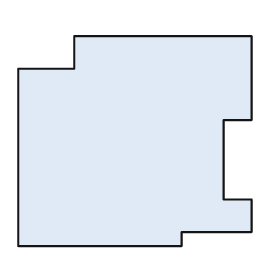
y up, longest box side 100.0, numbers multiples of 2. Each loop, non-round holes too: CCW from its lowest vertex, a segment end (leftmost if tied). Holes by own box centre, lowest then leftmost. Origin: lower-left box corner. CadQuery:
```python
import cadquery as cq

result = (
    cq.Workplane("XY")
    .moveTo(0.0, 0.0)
    .lineTo(70.0, 0.0)
    .lineTo(70.0, 6.0)
    .lineTo(100.0, 6.0)
    .lineTo(100.0, 20.0)
    .lineTo(88.0, 20.0)
    .lineTo(88.0, 54.0)
    .lineTo(100.0, 54.0)
    .lineTo(100.0, 90.0)
    .lineTo(24.0, 90.0)
    .lineTo(24.0, 76.0)
    .lineTo(0.0, 76.0)
    .close()
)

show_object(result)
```